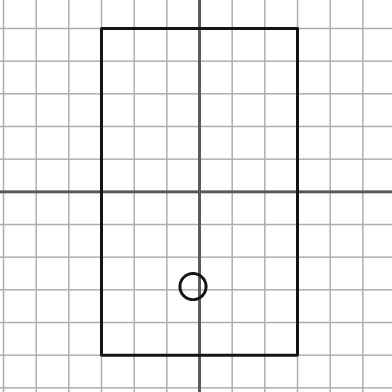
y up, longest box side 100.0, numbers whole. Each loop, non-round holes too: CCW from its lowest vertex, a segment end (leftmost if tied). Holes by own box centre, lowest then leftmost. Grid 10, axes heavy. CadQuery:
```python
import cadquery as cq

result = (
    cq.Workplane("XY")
    .moveTo(-30.0, -50.0)
    .lineTo(30.0, -50.0)
    .lineTo(30.0, 50.0)
    .lineTo(-30.0, 50.0)
    .close()
    .moveTo(-2.0, -29.0)
    .circle(4.0)
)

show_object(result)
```